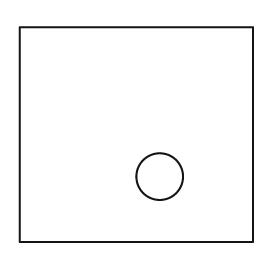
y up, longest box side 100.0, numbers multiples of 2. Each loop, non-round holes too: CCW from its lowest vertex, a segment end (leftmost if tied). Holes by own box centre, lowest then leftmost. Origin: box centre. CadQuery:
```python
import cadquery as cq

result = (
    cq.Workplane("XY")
    .moveTo(-50.0, -46.0)
    .lineTo(50.0, -46.0)
    .lineTo(50.0, 46.0)
    .lineTo(-50.0, 46.0)
    .close()
    .moveTo(10.0, -18.0)
    .circle(10.0)
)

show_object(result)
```